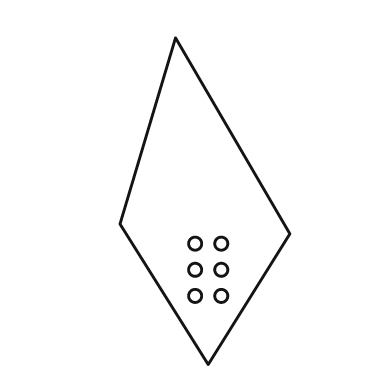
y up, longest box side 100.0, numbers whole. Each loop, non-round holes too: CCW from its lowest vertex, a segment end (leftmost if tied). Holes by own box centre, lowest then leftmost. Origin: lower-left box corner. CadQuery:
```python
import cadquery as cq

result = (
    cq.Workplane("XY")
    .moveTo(27.0, 0.0)
    .lineTo(52.0, 40.0)
    .lineTo(17.0, 100.0)
    .lineTo(0.0, 43.0)
    .close()
    .moveTo(23.0, 21.0)
    .circle(2.0)
    .moveTo(31.0, 21.0)
    .circle(2.0)
    .moveTo(23.0, 29.0)
    .circle(2.0)
    .moveTo(31.0, 29.0)
    .circle(2.0)
    .moveTo(23.0, 37.0)
    .circle(2.0)
    .moveTo(31.0, 37.0)
    .circle(2.0)
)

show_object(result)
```